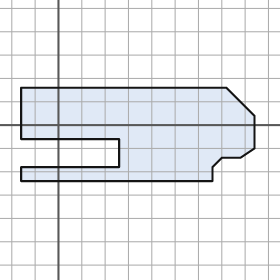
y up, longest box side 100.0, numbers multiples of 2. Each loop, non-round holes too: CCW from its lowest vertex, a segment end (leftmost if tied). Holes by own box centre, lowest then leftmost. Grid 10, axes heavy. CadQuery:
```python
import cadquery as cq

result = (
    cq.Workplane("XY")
    .moveTo(-16.0, -24.0)
    .lineTo(66.0, -24.0)
    .lineTo(66.0, -18.0)
    .lineTo(70.0, -14.0)
    .lineTo(78.0, -14.0)
    .lineTo(84.0, -10.0)
    .lineTo(84.0, 4.0)
    .lineTo(72.0, 16.0)
    .lineTo(-16.0, 16.0)
    .lineTo(-16.0, -6.0)
    .lineTo(26.0, -6.0)
    .lineTo(26.0, -18.0)
    .lineTo(-16.0, -18.0)
    .close()
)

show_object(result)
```